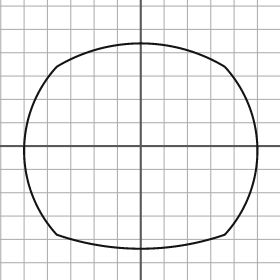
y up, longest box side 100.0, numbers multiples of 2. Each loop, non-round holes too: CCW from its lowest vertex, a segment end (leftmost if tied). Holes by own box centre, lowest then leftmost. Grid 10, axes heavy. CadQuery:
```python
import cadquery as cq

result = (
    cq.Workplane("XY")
    .moveTo(-36.0, -38.0)
    .threePointArc((0.0, -44.0), (36.0, -38.0))
    .threePointArc((50.0, -2.0), (36.0, 34.0))
    .threePointArc((0.0, 44.0), (-36.0, 34.0))
    .threePointArc((-50.0, -2.0), (-36.0, -38.0))
    .close()
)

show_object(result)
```